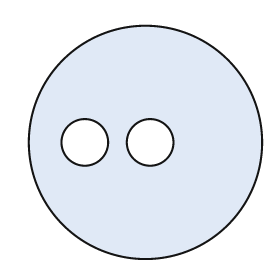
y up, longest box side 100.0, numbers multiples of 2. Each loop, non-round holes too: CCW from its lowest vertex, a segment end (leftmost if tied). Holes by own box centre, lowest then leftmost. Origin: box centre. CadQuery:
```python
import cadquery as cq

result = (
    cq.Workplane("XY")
    .moveTo(0.0, 0.0)
    .circle(50.0)
    .moveTo(-26.0, 0.0)
    .circle(10.0)
    .moveTo(2.0, 0.0)
    .circle(10.0)
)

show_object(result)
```